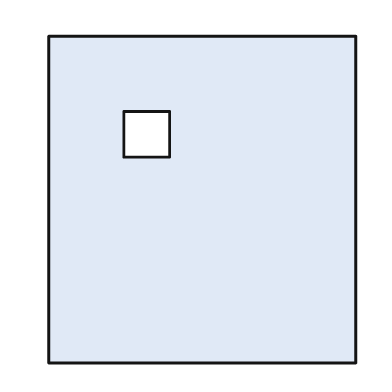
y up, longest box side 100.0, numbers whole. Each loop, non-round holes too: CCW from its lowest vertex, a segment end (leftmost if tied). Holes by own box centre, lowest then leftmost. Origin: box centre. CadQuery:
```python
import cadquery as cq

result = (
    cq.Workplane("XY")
    .moveTo(-47.0, -50.0)
    .lineTo(47.0, -50.0)
    .lineTo(47.0, 50.0)
    .lineTo(-47.0, 50.0)
    .close()
    .moveTo(-24.0, 13.0)
    .lineTo(-10.0, 13.0)
    .lineTo(-10.0, 27.0)
    .lineTo(-24.0, 27.0)
    .close()
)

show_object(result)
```